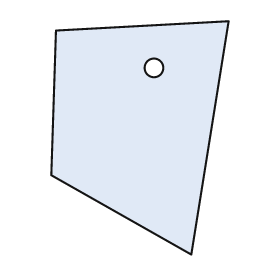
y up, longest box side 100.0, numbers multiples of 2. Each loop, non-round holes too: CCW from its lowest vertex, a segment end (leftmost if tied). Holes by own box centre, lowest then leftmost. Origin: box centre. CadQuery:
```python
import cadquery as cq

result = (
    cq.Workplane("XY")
    .moveTo(22.0, -50.0)
    .lineTo(38.0, 50.0)
    .lineTo(-36.0, 46.0)
    .lineTo(-38.0, -16.0)
    .close()
    .moveTo(6.0, 30.0)
    .circle(4.0)
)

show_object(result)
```